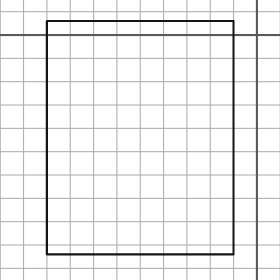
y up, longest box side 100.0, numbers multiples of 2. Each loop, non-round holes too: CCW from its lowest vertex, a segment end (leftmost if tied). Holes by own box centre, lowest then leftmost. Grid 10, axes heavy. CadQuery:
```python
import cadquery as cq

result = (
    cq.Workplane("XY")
    .moveTo(-90.0, -94.0)
    .lineTo(-10.0, -94.0)
    .lineTo(-10.0, 6.0)
    .lineTo(-90.0, 6.0)
    .close()
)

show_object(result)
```